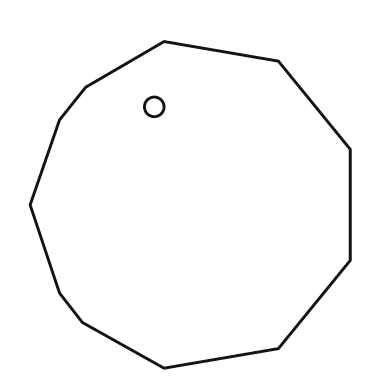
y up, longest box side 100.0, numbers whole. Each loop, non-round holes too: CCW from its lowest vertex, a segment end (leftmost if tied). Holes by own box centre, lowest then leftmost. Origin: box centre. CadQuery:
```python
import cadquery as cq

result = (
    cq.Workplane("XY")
    .moveTo(-8.0, -50.0)
    .lineTo(27.0, -44.0)
    .lineTo(49.0, -17.0)
    .lineTo(49.0, 17.0)
    .lineTo(27.0, 44.0)
    .lineTo(-8.0, 50.0)
    .lineTo(-32.0, 36.0)
    .lineTo(-40.0, 26.0)
    .lineTo(-49.0, 0.0)
    .lineTo(-40.0, -27.0)
    .lineTo(-33.0, -36.0)
    .close()
    .moveTo(-11.0, 30.0)
    .circle(3.0)
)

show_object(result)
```